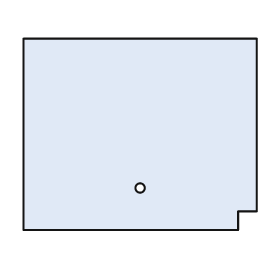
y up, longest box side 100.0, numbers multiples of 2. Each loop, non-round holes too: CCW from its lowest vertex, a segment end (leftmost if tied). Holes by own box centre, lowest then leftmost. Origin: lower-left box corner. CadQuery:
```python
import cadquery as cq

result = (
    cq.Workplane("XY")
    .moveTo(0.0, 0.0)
    .lineTo(92.0, 0.0)
    .lineTo(92.0, 8.0)
    .lineTo(100.0, 8.0)
    .lineTo(100.0, 82.0)
    .lineTo(0.0, 82.0)
    .close()
    .moveTo(50.0, 18.0)
    .circle(2.0)
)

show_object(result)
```